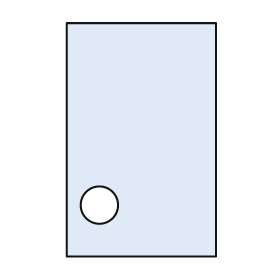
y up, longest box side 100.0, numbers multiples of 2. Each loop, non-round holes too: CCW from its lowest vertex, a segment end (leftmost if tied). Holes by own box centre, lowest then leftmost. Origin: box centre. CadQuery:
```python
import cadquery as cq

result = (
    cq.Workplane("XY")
    .moveTo(-32.0, -50.0)
    .lineTo(32.0, -50.0)
    .lineTo(32.0, 50.0)
    .lineTo(-32.0, 50.0)
    .close()
    .moveTo(-18.0, -28.0)
    .circle(8.0)
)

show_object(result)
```